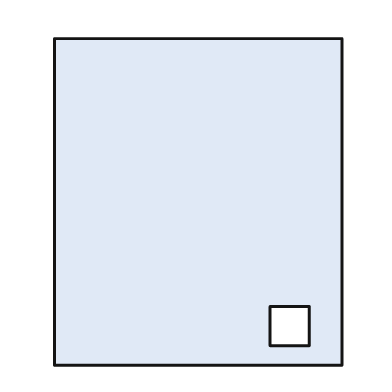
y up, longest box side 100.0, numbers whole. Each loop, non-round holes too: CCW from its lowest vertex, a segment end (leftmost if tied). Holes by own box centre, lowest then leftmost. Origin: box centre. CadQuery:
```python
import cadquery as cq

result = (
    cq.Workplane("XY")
    .moveTo(-44.0, -50.0)
    .lineTo(44.0, -50.0)
    .lineTo(44.0, 50.0)
    .lineTo(-44.0, 50.0)
    .close()
    .moveTo(22.0, -44.0)
    .lineTo(34.0, -44.0)
    .lineTo(34.0, -32.0)
    .lineTo(22.0, -32.0)
    .close()
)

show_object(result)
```